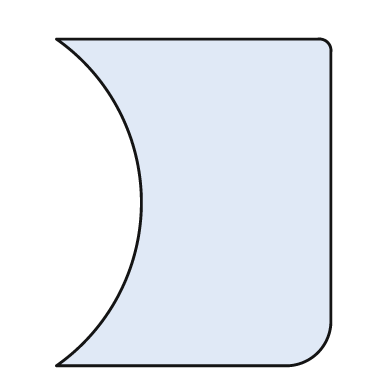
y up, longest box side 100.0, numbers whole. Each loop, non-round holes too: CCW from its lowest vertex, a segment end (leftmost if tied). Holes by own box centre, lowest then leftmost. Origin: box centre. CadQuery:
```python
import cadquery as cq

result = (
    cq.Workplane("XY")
    .moveTo(-42.0, -50.0)
    .lineTo(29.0, -50.0)
    .threePointArc((38.0, -46.0), (42.0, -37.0))
    .lineTo(42.0, 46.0)
    .threePointArc((41.0, 49.0), (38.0, 50.0))
    .lineTo(-42.0, 50.0)
    .threePointArc((-16.0, 0.0), (-42.0, -50.0))
    .close()
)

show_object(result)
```